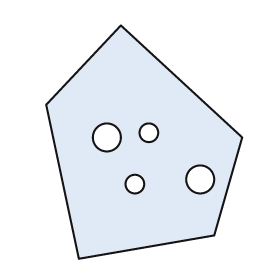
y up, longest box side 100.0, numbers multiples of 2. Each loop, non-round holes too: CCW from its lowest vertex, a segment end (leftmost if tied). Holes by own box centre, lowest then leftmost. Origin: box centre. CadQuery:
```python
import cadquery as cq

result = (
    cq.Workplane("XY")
    .moveTo(-28.0, -50.0)
    .lineTo(30.0, -40.0)
    .lineTo(42.0, 2.0)
    .lineTo(-10.0, 50.0)
    .lineTo(-42.0, 16.0)
    .close()
    .moveTo(-4.0, -18.0)
    .circle(4.0)
    .moveTo(24.0, -16.0)
    .circle(6.0)
    .moveTo(-16.0, 2.0)
    .circle(6.0)
    .moveTo(2.0, 4.0)
    .circle(4.0)
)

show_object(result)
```